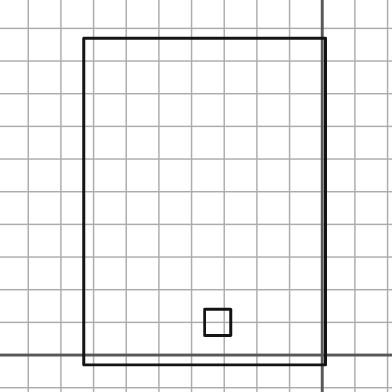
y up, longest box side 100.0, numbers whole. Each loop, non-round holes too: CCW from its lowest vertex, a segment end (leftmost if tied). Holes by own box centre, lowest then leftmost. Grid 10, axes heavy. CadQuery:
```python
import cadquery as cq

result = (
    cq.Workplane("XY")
    .moveTo(-73.0, -3.0)
    .lineTo(1.0, -3.0)
    .lineTo(1.0, 97.0)
    .lineTo(-73.0, 97.0)
    .close()
    .moveTo(-36.0, 6.0)
    .lineTo(-28.0, 6.0)
    .lineTo(-28.0, 14.0)
    .lineTo(-36.0, 14.0)
    .close()
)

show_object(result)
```